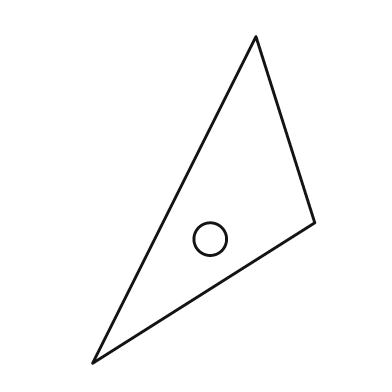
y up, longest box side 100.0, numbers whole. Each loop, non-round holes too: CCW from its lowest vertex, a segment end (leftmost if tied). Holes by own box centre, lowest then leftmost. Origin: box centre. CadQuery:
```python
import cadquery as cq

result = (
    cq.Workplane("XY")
    .moveTo(-34.0, -50.0)
    .lineTo(34.0, -7.0)
    .lineTo(16.0, 50.0)
    .close()
    .moveTo(2.0, -12.0)
    .circle(5.0)
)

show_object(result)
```